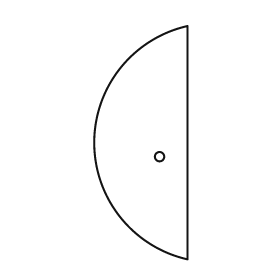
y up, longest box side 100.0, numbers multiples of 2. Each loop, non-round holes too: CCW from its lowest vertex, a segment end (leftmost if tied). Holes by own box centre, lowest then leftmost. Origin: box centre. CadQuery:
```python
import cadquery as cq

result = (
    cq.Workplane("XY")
    .moveTo(20.0, -50.0)
    .lineTo(20.0, 50.0)
    .threePointArc((-20.0, 0.0), (20.0, -50.0))
    .close()
    .moveTo(8.0, -6.0)
    .circle(2.0)
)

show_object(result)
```